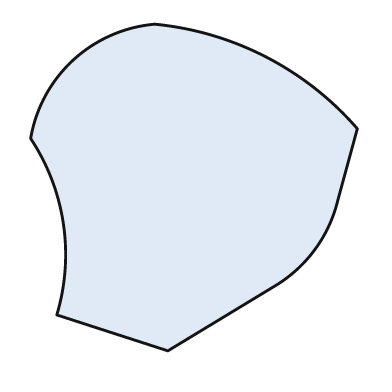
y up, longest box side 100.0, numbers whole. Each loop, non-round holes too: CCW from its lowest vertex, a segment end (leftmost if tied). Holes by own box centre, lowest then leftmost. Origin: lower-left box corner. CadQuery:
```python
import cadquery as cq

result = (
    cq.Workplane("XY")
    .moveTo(42.0, 0.0)
    .lineTo(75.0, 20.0)
    .threePointArc((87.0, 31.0), (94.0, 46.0))
    .lineTo(100.0, 68.0)
    .threePointArc((72.0, 90.0), (38.0, 100.0))
    .threePointArc((13.0, 89.0), (0.0, 65.0))
    .threePointArc((10.0, 39.0), (8.0, 11.0))
    .close()
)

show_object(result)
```